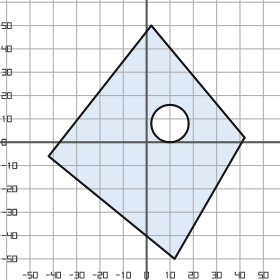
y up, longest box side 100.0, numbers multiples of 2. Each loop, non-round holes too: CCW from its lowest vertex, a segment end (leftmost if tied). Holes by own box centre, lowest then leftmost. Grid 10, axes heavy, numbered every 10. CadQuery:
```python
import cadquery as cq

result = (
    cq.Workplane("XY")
    .moveTo(12.0, -50.0)
    .lineTo(42.0, 2.0)
    .lineTo(2.0, 50.0)
    .lineTo(-42.0, -6.0)
    .close()
    .moveTo(10.0, 8.0)
    .circle(8.0)
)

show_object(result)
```